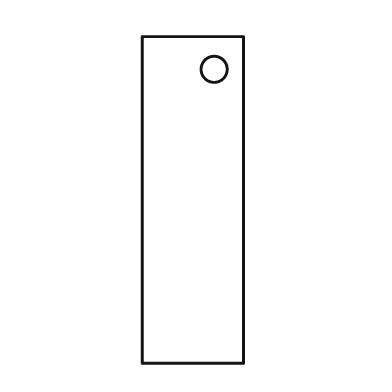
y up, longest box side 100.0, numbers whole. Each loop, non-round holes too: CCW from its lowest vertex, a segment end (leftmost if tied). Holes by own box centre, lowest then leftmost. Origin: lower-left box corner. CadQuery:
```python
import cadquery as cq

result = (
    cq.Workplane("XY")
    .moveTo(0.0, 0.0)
    .lineTo(31.0, 0.0)
    .lineTo(31.0, 100.0)
    .lineTo(0.0, 100.0)
    .close()
    .moveTo(22.0, 90.0)
    .circle(4.0)
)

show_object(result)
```